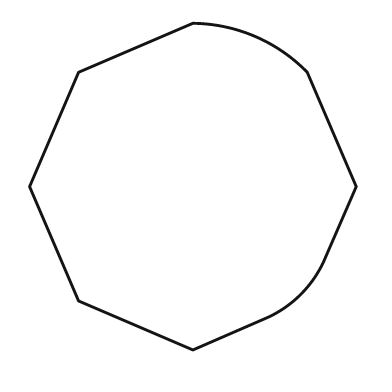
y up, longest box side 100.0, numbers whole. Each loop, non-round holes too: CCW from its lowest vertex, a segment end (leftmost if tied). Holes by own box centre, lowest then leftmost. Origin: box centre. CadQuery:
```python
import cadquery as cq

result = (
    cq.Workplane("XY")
    .moveTo(0.0, -50.0)
    .lineTo(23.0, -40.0)
    .threePointArc((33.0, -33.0), (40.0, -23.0))
    .lineTo(50.0, 0.0)
    .lineTo(35.0, 35.0)
    .threePointArc((19.0, 46.0), (0.0, 50.0))
    .lineTo(-35.0, 35.0)
    .lineTo(-50.0, 0.0)
    .lineTo(-35.0, -35.0)
    .close()
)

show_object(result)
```